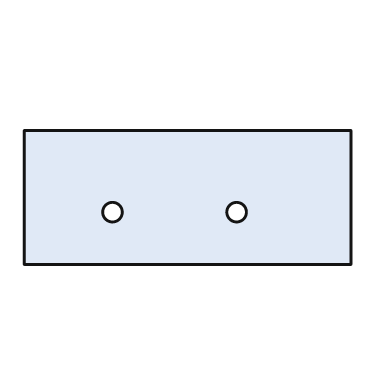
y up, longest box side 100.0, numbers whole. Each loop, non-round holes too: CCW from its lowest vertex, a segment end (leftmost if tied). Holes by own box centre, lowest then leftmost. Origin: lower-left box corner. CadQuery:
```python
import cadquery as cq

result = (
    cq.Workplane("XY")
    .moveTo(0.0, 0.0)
    .lineTo(100.0, 0.0)
    .lineTo(100.0, 41.0)
    .lineTo(0.0, 41.0)
    .close()
    .moveTo(27.0, 16.0)
    .circle(3.0)
    .moveTo(65.0, 16.0)
    .circle(3.0)
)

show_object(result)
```